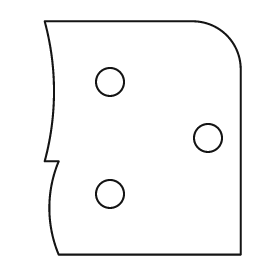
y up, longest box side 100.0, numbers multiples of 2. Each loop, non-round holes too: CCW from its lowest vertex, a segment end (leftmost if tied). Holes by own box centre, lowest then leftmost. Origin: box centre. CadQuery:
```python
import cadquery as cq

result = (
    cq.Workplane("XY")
    .moveTo(-36.0, -50.0)
    .lineTo(42.0, -50.0)
    .lineTo(42.0, 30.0)
    .threePointArc((36.0, 44.0), (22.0, 50.0))
    .lineTo(-42.0, 50.0)
    .threePointArc((-38.0, 20.0), (-42.0, -10.0))
    .lineTo(-36.0, -10.0)
    .threePointArc((-40.0, -30.0), (-36.0, -50.0))
    .close()
    .moveTo(-14.0, -24.0)
    .circle(6.0)
    .moveTo(28.0, 0.0)
    .circle(6.0)
    .moveTo(-14.0, 24.0)
    .circle(6.0)
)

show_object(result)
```